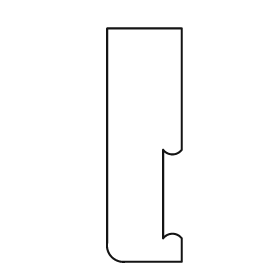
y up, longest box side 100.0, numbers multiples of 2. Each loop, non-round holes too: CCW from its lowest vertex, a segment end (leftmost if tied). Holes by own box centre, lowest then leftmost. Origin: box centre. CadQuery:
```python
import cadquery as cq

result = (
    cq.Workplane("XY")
    .moveTo(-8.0, -50.0)
    .lineTo(16.0, -50.0)
    .lineTo(16.0, -40.0)
    .threePointArc((12.0, -38.0), (8.0, -40.0))
    .lineTo(8.0, -2.0)
    .threePointArc((12.0, -4.0), (16.0, -2.0))
    .lineTo(16.0, 50.0)
    .lineTo(-16.0, 50.0)
    .lineTo(-16.0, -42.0)
    .threePointArc((-14.0, -48.0), (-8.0, -50.0))
    .close()
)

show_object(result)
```